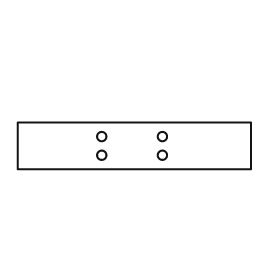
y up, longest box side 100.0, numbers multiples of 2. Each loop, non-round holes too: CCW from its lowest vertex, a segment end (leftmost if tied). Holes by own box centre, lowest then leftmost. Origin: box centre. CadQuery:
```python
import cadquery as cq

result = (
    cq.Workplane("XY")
    .moveTo(-50.0, -10.0)
    .lineTo(50.0, -10.0)
    .lineTo(50.0, 10.0)
    .lineTo(-50.0, 10.0)
    .close()
    .moveTo(-14.0, -4.0)
    .circle(2.0)
    .moveTo(12.0, -4.0)
    .circle(2.0)
    .moveTo(-14.0, 4.0)
    .circle(2.0)
    .moveTo(12.0, 4.0)
    .circle(2.0)
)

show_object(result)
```